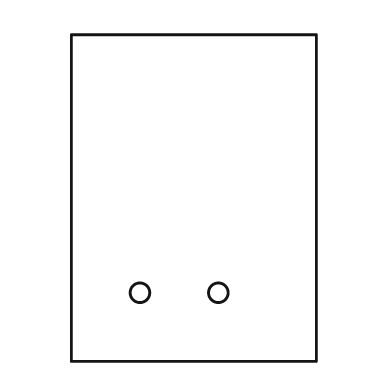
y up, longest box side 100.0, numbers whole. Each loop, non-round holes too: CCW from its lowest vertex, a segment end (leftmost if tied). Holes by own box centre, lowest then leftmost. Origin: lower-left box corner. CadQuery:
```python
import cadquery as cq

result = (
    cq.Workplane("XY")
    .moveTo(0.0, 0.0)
    .lineTo(75.0, 0.0)
    .lineTo(75.0, 100.0)
    .lineTo(0.0, 100.0)
    .close()
    .moveTo(21.0, 21.0)
    .circle(3.0)
    .moveTo(45.0, 21.0)
    .circle(3.0)
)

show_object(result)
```